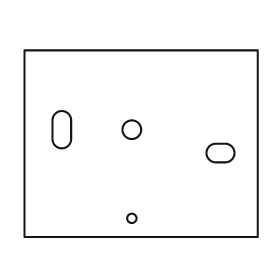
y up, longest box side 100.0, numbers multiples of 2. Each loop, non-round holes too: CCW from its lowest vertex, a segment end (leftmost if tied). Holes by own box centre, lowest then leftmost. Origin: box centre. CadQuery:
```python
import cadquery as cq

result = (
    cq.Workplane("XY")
    .moveTo(-50.0, -40.0)
    .lineTo(50.0, -40.0)
    .lineTo(50.0, 40.0)
    .lineTo(-50.0, 40.0)
    .close()
    .moveTo(-4.0, -32.0)
    .circle(2.0)
    .moveTo(32.0, -8.0)
    .lineTo(36.0, -8.0)
    .threePointArc((40.0, -4.0), (36.0, 0.0))
    .lineTo(32.0, 0.0)
    .threePointArc((28.0, -4.0), (32.0, -8.0))
    .close()
    .moveTo(-38.0, 2.0)
    .threePointArc((-34.0, -2.0), (-30.0, 2.0))
    .lineTo(-30.0, 10.0)
    .threePointArc((-34.0, 14.0), (-38.0, 10.0))
    .close()
    .moveTo(-4.0, 6.0)
    .circle(4.0)
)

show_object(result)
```